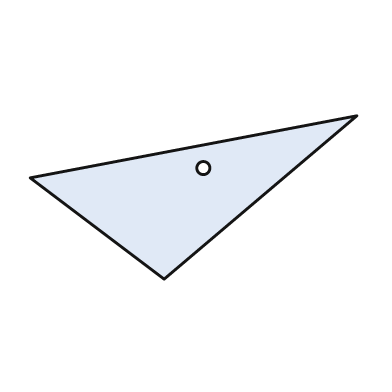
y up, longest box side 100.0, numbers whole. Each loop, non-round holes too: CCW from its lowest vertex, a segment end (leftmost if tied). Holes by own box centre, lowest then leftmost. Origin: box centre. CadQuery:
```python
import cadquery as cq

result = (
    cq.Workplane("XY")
    .moveTo(-9.0, -25.0)
    .lineTo(50.0, 25.0)
    .lineTo(-50.0, 6.0)
    .close()
    .moveTo(3.0, 9.0)
    .circle(2.0)
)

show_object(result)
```